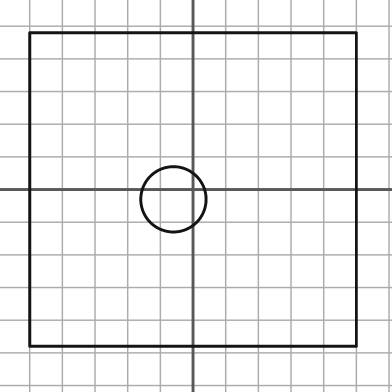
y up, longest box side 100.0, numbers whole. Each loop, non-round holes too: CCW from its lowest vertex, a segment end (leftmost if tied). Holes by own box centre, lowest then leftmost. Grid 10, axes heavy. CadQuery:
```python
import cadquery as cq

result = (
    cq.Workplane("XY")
    .moveTo(-50.0, -48.0)
    .lineTo(50.0, -48.0)
    .lineTo(50.0, 48.0)
    .lineTo(-50.0, 48.0)
    .close()
    .moveTo(-6.0, -3.0)
    .circle(10.0)
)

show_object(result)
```